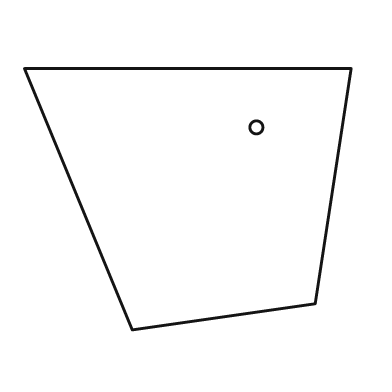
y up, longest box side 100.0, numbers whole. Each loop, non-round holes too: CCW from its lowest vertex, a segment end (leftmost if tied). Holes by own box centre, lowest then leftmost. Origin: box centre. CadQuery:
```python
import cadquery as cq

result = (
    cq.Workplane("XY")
    .moveTo(-17.0, -40.0)
    .lineTo(39.0, -32.0)
    .lineTo(50.0, 40.0)
    .lineTo(-50.0, 40.0)
    .close()
    .moveTo(21.0, 22.0)
    .circle(2.0)
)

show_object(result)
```